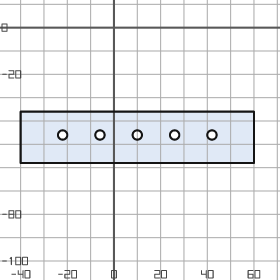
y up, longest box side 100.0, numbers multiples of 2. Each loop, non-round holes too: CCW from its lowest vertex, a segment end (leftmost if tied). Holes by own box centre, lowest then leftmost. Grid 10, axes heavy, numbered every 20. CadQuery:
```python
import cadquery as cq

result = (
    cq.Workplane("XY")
    .moveTo(-40.0, -58.0)
    .lineTo(60.0, -58.0)
    .lineTo(60.0, -36.0)
    .lineTo(-40.0, -36.0)
    .close()
    .moveTo(-22.0, -46.0)
    .circle(2.0)
    .moveTo(-6.0, -46.0)
    .circle(2.0)
    .moveTo(10.0, -46.0)
    .circle(2.0)
    .moveTo(26.0, -46.0)
    .circle(2.0)
    .moveTo(42.0, -46.0)
    .circle(2.0)
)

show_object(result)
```